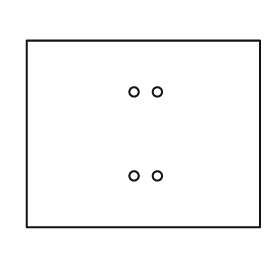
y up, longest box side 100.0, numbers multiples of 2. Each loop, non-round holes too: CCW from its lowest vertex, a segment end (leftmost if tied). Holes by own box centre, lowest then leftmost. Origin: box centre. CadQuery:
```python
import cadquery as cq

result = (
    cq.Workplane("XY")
    .moveTo(-50.0, -40.0)
    .lineTo(50.0, -40.0)
    .lineTo(50.0, 40.0)
    .lineTo(-50.0, 40.0)
    .close()
    .moveTo(-4.0, -18.0)
    .circle(2.0)
    .moveTo(6.0, -18.0)
    .circle(2.0)
    .moveTo(-4.0, 18.0)
    .circle(2.0)
    .moveTo(6.0, 18.0)
    .circle(2.0)
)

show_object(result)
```